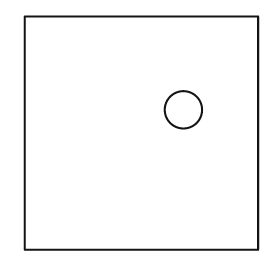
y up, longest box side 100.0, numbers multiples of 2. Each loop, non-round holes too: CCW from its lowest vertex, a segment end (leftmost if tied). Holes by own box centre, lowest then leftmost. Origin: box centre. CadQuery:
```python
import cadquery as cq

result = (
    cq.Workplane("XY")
    .moveTo(-50.0, -50.0)
    .lineTo(50.0, -50.0)
    .lineTo(50.0, 50.0)
    .lineTo(-50.0, 50.0)
    .close()
    .moveTo(18.0, 10.0)
    .circle(8.0)
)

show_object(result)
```